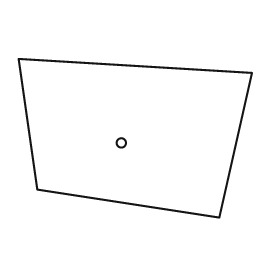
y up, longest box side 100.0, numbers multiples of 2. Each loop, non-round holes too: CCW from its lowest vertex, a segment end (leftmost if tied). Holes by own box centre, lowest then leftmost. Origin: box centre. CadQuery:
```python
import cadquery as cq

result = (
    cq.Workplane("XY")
    .moveTo(36.0, -34.0)
    .lineTo(50.0, 28.0)
    .lineTo(-50.0, 34.0)
    .lineTo(-42.0, -22.0)
    .close()
    .moveTo(-6.0, -2.0)
    .circle(2.0)
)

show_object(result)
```